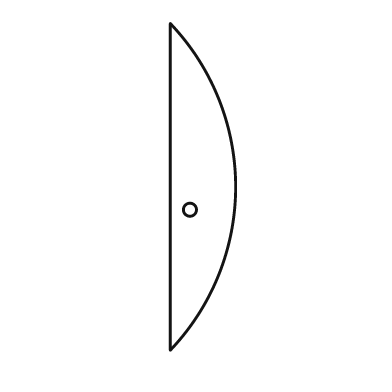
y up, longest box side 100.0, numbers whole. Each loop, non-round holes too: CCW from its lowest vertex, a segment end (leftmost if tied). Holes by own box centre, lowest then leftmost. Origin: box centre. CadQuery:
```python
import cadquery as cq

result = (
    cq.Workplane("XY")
    .moveTo(-10.0, -50.0)
    .threePointArc((10.0, 0.0), (-10.0, 50.0))
    .close()
    .moveTo(-4.0, -7.0)
    .circle(2.0)
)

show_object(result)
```